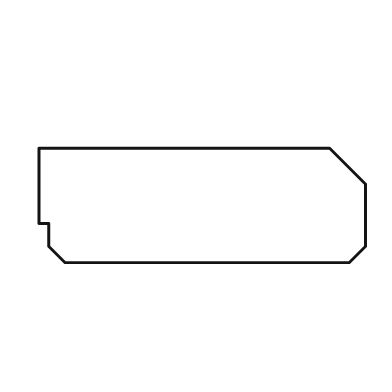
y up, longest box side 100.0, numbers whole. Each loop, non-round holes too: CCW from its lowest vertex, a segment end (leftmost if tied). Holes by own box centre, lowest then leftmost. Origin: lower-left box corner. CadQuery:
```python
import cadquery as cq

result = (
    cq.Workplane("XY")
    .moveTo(8.0, 0.0)
    .lineTo(95.0, 0.0)
    .lineTo(100.0, 5.0)
    .lineTo(100.0, 24.0)
    .lineTo(89.0, 35.0)
    .lineTo(0.0, 35.0)
    .lineTo(0.0, 12.0)
    .lineTo(3.0, 12.0)
    .lineTo(3.0, 5.0)
    .close()
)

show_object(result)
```